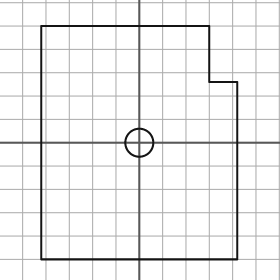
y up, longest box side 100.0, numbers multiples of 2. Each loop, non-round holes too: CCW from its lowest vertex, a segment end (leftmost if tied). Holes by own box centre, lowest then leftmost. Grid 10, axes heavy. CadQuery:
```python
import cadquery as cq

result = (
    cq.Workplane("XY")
    .moveTo(-42.0, -50.0)
    .lineTo(42.0, -50.0)
    .lineTo(42.0, 26.0)
    .lineTo(30.0, 26.0)
    .lineTo(30.0, 50.0)
    .lineTo(-42.0, 50.0)
    .close()
    .moveTo(0.0, 0.0)
    .circle(6.0)
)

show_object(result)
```